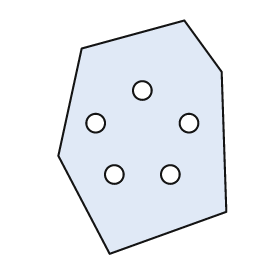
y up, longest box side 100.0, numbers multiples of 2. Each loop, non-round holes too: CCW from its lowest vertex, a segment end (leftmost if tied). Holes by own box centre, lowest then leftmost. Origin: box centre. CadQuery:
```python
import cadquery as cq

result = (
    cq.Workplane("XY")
    .moveTo(-14.0, -50.0)
    .lineTo(36.0, -32.0)
    .lineTo(34.0, 28.0)
    .lineTo(18.0, 50.0)
    .lineTo(-26.0, 38.0)
    .lineTo(-36.0, -8.0)
    .close()
    .moveTo(-12.0, -16.0)
    .circle(4.0)
    .moveTo(12.0, -16.0)
    .circle(4.0)
    .moveTo(-20.0, 6.0)
    .circle(4.0)
    .moveTo(20.0, 6.0)
    .circle(4.0)
    .moveTo(0.0, 20.0)
    .circle(4.0)
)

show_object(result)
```